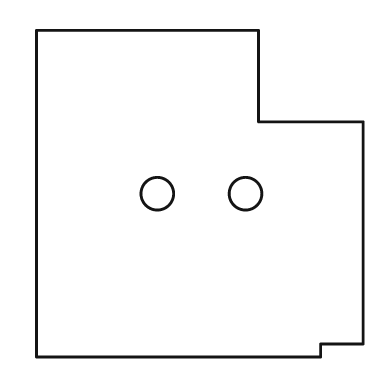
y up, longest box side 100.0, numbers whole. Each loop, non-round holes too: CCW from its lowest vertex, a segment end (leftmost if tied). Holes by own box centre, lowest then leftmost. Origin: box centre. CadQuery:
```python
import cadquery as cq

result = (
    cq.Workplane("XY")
    .moveTo(-50.0, -50.0)
    .lineTo(37.0, -50.0)
    .lineTo(37.0, -46.0)
    .lineTo(50.0, -46.0)
    .lineTo(50.0, 22.0)
    .lineTo(18.0, 22.0)
    .lineTo(18.0, 50.0)
    .lineTo(-50.0, 50.0)
    .close()
    .moveTo(-13.0, 0.0)
    .circle(5.0)
    .moveTo(14.0, 0.0)
    .circle(5.0)
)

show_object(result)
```